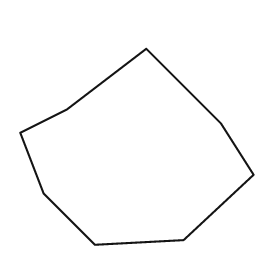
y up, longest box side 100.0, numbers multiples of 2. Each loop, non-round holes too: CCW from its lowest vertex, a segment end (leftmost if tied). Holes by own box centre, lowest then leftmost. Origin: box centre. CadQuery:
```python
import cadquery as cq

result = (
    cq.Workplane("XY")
    .moveTo(-18.0, -42.0)
    .lineTo(20.0, -40.0)
    .lineTo(50.0, -12.0)
    .lineTo(36.0, 10.0)
    .lineTo(4.0, 42.0)
    .lineTo(-30.0, 16.0)
    .lineTo(-50.0, 6.0)
    .lineTo(-40.0, -20.0)
    .close()
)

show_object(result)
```